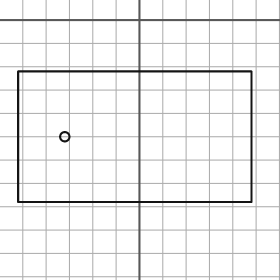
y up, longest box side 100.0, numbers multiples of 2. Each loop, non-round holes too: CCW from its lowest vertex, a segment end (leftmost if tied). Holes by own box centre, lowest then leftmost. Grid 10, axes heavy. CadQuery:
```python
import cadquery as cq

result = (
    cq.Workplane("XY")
    .moveTo(-52.0, -78.0)
    .lineTo(48.0, -78.0)
    .lineTo(48.0, -22.0)
    .lineTo(-52.0, -22.0)
    .close()
    .moveTo(-32.0, -50.0)
    .circle(2.0)
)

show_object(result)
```